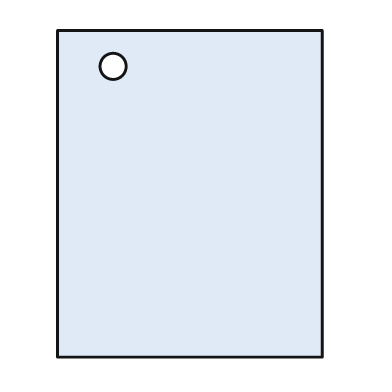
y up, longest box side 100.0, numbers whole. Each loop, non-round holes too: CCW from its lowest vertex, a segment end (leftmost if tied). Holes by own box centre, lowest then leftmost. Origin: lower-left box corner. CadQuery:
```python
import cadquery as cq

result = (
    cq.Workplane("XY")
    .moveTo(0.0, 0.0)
    .lineTo(81.0, 0.0)
    .lineTo(81.0, 100.0)
    .lineTo(0.0, 100.0)
    .close()
    .moveTo(17.0, 89.0)
    .circle(4.0)
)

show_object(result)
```